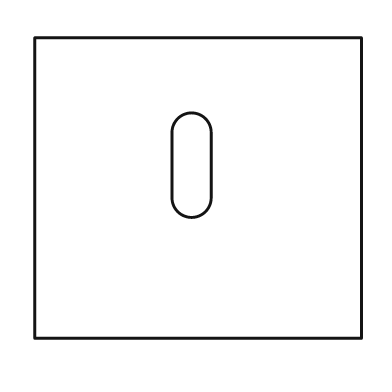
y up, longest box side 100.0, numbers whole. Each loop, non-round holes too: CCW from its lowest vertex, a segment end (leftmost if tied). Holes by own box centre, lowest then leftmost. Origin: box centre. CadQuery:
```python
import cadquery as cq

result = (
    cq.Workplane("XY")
    .moveTo(-50.0, -46.0)
    .lineTo(50.0, -46.0)
    .lineTo(50.0, 46.0)
    .lineTo(-50.0, 46.0)
    .close()
    .moveTo(-8.0, -3.0)
    .threePointArc((-2.0, -9.0), (4.0, -3.0))
    .lineTo(4.0, 17.0)
    .threePointArc((-2.0, 23.0), (-8.0, 17.0))
    .close()
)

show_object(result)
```